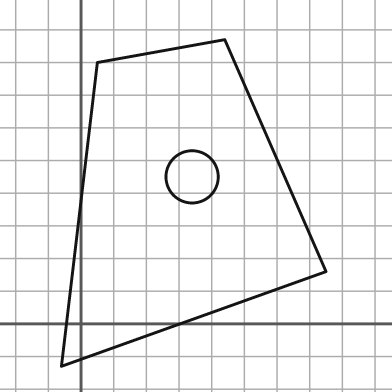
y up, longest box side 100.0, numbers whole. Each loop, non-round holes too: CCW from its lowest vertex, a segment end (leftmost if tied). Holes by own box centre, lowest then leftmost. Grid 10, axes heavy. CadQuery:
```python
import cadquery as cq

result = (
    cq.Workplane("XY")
    .moveTo(-6.0, -13.0)
    .lineTo(75.0, 16.0)
    .lineTo(44.0, 87.0)
    .lineTo(5.0, 80.0)
    .close()
    .moveTo(34.0, 45.0)
    .circle(8.0)
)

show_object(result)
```